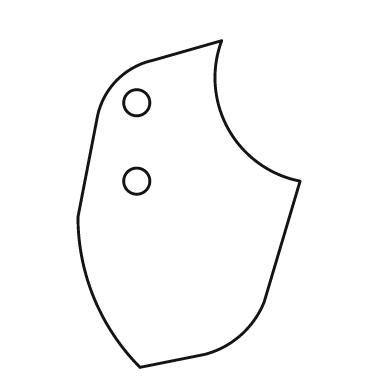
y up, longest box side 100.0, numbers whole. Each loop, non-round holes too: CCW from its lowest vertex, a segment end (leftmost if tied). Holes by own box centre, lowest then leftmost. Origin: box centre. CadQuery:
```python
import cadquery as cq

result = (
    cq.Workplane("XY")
    .moveTo(-15.0, -50.0)
    .lineTo(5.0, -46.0)
    .threePointArc((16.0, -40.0), (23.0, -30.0))
    .lineTo(34.0, 7.0)
    .threePointArc((12.0, 23.0), (10.0, 50.0))
    .lineTo(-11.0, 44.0)
    .threePointArc((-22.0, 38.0), (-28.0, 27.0))
    .lineTo(-34.0, -4.0)
    .threePointArc((-29.0, -29.0), (-15.0, -50.0))
    .close()
    .moveTo(-16.0, 7.0)
    .circle(4.0)
    .moveTo(-16.0, 31.0)
    .circle(4.0)
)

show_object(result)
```